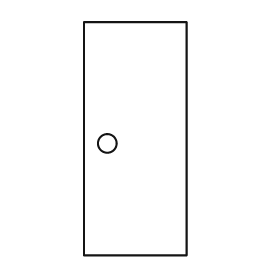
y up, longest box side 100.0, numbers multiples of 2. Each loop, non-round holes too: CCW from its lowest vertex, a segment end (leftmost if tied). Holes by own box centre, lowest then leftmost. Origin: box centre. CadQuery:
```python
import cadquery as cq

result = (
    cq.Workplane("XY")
    .moveTo(-22.0, -50.0)
    .lineTo(22.0, -50.0)
    .lineTo(22.0, 50.0)
    .lineTo(-22.0, 50.0)
    .close()
    .moveTo(-12.0, -2.0)
    .circle(4.0)
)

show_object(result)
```